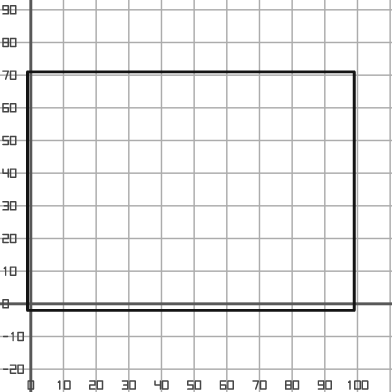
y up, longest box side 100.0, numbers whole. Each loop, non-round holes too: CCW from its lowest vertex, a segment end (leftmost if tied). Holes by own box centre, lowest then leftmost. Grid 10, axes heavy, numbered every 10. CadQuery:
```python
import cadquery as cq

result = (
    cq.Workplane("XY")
    .moveTo(-1.0, -2.0)
    .lineTo(99.0, -2.0)
    .lineTo(99.0, 71.0)
    .lineTo(-1.0, 71.0)
    .close()
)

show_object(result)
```